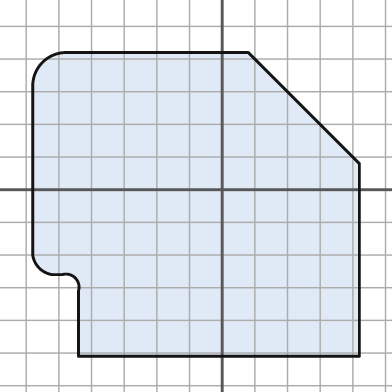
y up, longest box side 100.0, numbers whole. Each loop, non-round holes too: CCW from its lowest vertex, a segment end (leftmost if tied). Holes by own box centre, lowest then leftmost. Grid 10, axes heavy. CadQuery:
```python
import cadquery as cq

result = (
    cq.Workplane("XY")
    .moveTo(-44.0, -51.0)
    .lineTo(42.0, -51.0)
    .lineTo(42.0, 8.0)
    .lineTo(8.0, 42.0)
    .lineTo(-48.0, 42.0)
    .threePointArc((-55.0, 39.0), (-58.0, 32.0))
    .lineTo(-58.0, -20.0)
    .threePointArc((-56.0, -24.0), (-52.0, -26.0))
    .lineTo(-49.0, -26.0)
    .threePointArc((-45.0, -27.0), (-44.0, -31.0))
    .close()
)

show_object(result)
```